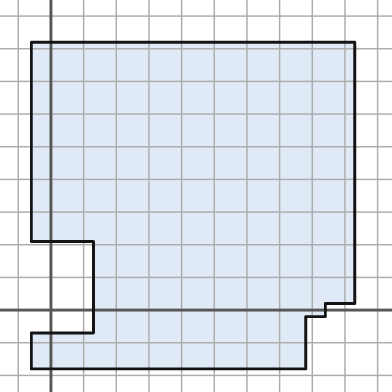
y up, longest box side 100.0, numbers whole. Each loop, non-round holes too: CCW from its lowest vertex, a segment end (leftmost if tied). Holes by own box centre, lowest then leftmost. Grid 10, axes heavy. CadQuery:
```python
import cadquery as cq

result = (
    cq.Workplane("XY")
    .moveTo(-6.0, -18.0)
    .lineTo(78.0, -18.0)
    .lineTo(78.0, -2.0)
    .lineTo(84.0, -2.0)
    .lineTo(84.0, 2.0)
    .lineTo(93.0, 2.0)
    .lineTo(93.0, 82.0)
    .lineTo(-6.0, 82.0)
    .lineTo(-6.0, 21.0)
    .lineTo(13.0, 21.0)
    .lineTo(13.0, -7.0)
    .lineTo(-6.0, -7.0)
    .close()
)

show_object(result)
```